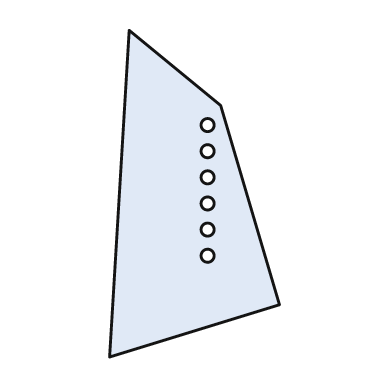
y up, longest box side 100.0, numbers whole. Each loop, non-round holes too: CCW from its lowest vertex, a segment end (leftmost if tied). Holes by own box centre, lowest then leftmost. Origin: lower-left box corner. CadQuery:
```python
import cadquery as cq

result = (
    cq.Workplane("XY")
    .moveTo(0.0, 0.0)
    .lineTo(52.0, 16.0)
    .lineTo(34.0, 77.0)
    .lineTo(6.0, 100.0)
    .close()
    .moveTo(30.0, 31.0)
    .circle(2.0)
    .moveTo(30.0, 39.0)
    .circle(2.0)
    .moveTo(30.0, 47.0)
    .circle(2.0)
    .moveTo(30.0, 55.0)
    .circle(2.0)
    .moveTo(30.0, 63.0)
    .circle(2.0)
    .moveTo(30.0, 71.0)
    .circle(2.0)
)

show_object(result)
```